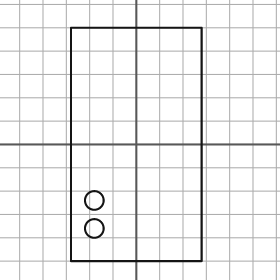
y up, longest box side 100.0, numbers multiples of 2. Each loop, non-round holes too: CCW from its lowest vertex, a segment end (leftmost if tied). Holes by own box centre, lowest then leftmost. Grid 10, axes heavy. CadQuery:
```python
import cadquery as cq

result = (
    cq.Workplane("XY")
    .moveTo(-28.0, -50.0)
    .lineTo(28.0, -50.0)
    .lineTo(28.0, 50.0)
    .lineTo(-28.0, 50.0)
    .close()
    .moveTo(-18.0, -36.0)
    .circle(4.0)
    .moveTo(-18.0, -24.0)
    .circle(4.0)
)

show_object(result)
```